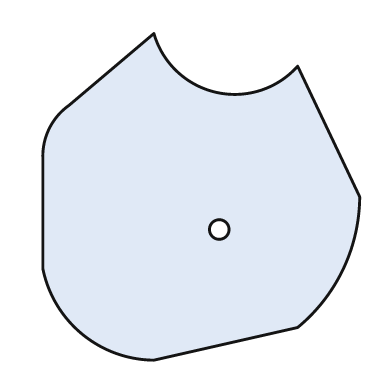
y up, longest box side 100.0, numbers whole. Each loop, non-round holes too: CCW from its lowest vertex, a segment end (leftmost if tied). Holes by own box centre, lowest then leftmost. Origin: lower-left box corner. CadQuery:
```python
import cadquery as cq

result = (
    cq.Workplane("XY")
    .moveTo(34.0, 0.0)
    .lineTo(78.0, 10.0)
    .threePointArc((92.0, 28.0), (97.0, 50.0))
    .lineTo(78.0, 90.0)
    .threePointArc((53.0, 82.0), (34.0, 100.0))
    .lineTo(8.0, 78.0)
    .threePointArc((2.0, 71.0), (0.0, 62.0))
    .lineTo(0.0, 28.0)
    .threePointArc((12.0, 8.0), (34.0, 0.0))
    .close()
    .moveTo(54.0, 40.0)
    .circle(3.0)
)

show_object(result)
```